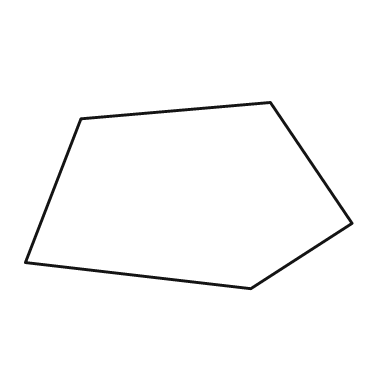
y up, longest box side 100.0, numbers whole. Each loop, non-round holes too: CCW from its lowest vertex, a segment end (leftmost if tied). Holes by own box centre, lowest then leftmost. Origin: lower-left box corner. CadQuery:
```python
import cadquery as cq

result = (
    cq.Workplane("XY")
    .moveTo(69.0, 0.0)
    .lineTo(100.0, 20.0)
    .lineTo(75.0, 57.0)
    .lineTo(17.0, 52.0)
    .lineTo(0.0, 8.0)
    .close()
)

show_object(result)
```